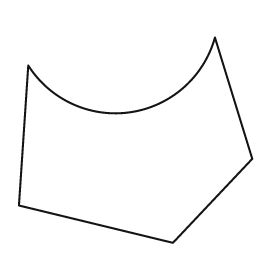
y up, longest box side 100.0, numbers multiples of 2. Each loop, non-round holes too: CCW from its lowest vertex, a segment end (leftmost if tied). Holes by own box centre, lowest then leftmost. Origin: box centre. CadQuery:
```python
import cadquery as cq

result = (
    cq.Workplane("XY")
    .moveTo(16.0, -44.0)
    .lineTo(50.0, -8.0)
    .lineTo(34.0, 44.0)
    .threePointArc((-2.0, 12.0), (-46.0, 32.0))
    .lineTo(-50.0, -28.0)
    .close()
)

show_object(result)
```